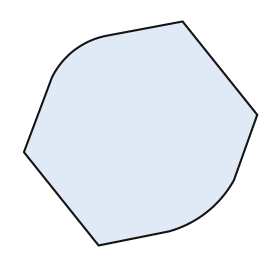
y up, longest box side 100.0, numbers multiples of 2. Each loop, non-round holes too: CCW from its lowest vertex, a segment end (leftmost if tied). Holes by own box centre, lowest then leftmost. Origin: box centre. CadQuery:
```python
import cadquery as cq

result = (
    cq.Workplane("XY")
    .moveTo(-18.0, -48.0)
    .lineTo(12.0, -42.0)
    .threePointArc((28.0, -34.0), (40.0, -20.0))
    .lineTo(50.0, 8.0)
    .lineTo(18.0, 48.0)
    .lineTo(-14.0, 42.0)
    .threePointArc((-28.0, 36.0), (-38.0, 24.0))
    .lineTo(-50.0, -8.0)
    .close()
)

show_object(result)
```